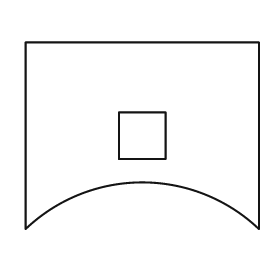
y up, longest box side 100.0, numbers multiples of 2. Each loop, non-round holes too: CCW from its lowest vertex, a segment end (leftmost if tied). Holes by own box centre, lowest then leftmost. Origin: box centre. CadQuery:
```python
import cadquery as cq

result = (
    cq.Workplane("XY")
    .moveTo(-50.0, -40.0)
    .threePointArc((0.0, -20.0), (50.0, -40.0))
    .lineTo(50.0, 40.0)
    .lineTo(-50.0, 40.0)
    .close()
    .moveTo(-10.0, -10.0)
    .lineTo(10.0, -10.0)
    .lineTo(10.0, 10.0)
    .lineTo(-10.0, 10.0)
    .close()
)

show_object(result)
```